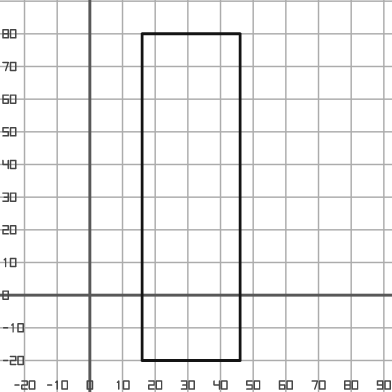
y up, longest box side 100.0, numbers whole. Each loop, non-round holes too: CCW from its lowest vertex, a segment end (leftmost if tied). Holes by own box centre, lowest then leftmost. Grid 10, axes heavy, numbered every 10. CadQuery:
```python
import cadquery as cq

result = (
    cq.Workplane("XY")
    .moveTo(16.0, -20.0)
    .lineTo(46.0, -20.0)
    .lineTo(46.0, 80.0)
    .lineTo(16.0, 80.0)
    .close()
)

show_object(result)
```